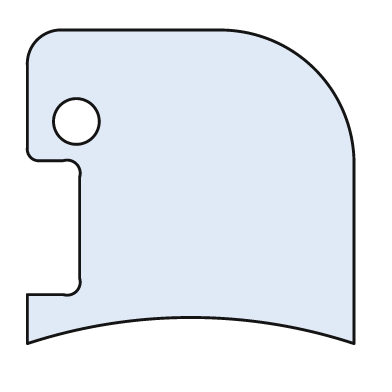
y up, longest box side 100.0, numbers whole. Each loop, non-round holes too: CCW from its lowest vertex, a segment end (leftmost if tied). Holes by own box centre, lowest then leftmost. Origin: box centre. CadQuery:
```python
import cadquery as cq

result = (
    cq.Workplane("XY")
    .moveTo(-50.0, -48.0)
    .threePointArc((0.0, -40.0), (50.0, -48.0))
    .lineTo(50.0, 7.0)
    .threePointArc((38.0, 36.0), (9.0, 48.0))
    .lineTo(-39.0, 48.0)
    .threePointArc((-47.0, 45.0), (-50.0, 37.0))
    .lineTo(-50.0, 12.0)
    .threePointArc((-49.0, 9.0), (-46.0, 8.0))
    .lineTo(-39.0, 8.0)
    .threePointArc((-35.0, 7.0), (-34.0, 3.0))
    .lineTo(-34.0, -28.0)
    .threePointArc((-35.0, -32.0), (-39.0, -33.0))
    .lineTo(-50.0, -33.0)
    .close()
    .moveTo(-35.0, 20.0)
    .circle(7.0)
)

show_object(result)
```